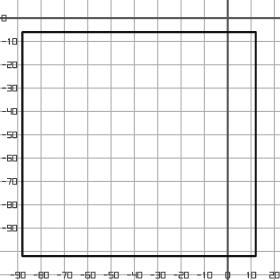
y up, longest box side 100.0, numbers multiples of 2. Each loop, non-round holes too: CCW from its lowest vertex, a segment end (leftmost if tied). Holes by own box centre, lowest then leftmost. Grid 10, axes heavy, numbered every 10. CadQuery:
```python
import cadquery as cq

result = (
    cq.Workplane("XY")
    .moveTo(-88.0, -102.0)
    .lineTo(12.0, -102.0)
    .lineTo(12.0, -6.0)
    .lineTo(-88.0, -6.0)
    .close()
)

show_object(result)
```